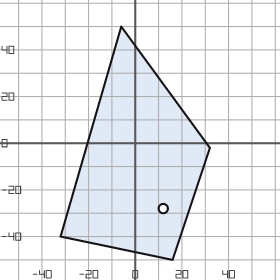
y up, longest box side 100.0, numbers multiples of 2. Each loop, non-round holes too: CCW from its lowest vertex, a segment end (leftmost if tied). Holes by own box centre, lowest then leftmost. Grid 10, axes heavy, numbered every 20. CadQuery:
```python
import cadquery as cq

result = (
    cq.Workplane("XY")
    .moveTo(16.0, -50.0)
    .lineTo(32.0, -2.0)
    .lineTo(-6.0, 50.0)
    .lineTo(-32.0, -40.0)
    .close()
    .moveTo(12.0, -28.0)
    .circle(2.0)
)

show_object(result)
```